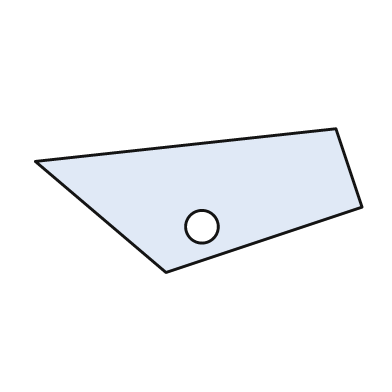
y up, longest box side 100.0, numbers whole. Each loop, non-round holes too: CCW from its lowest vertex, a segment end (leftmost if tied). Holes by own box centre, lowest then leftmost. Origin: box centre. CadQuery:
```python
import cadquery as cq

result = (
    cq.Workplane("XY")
    .moveTo(-10.0, -22.0)
    .lineTo(50.0, -2.0)
    .lineTo(42.0, 22.0)
    .lineTo(-50.0, 12.0)
    .close()
    .moveTo(1.0, -8.0)
    .circle(5.0)
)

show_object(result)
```